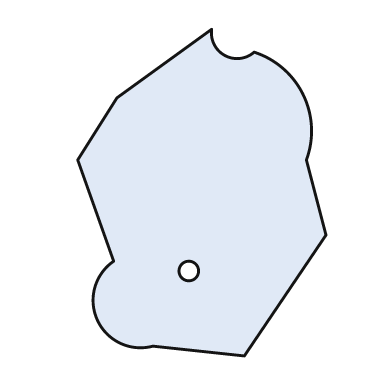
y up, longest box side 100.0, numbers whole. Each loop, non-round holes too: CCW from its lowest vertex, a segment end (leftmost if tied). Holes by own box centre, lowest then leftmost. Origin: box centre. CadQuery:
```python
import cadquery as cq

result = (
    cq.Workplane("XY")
    .moveTo(13.0, -50.0)
    .lineTo(38.0, -13.0)
    .lineTo(32.0, 10.0)
    .threePointArc((31.0, 30.0), (16.0, 43.0))
    .threePointArc((7.0, 42.0), (3.0, 50.0))
    .lineTo(-26.0, 29.0)
    .lineTo(-38.0, 10.0)
    .lineTo(-27.0, -21.0)
    .threePointArc((-32.0, -39.0), (-15.0, -47.0))
    .close()
    .moveTo(-4.0, -24.0)
    .circle(3.0)
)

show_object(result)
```